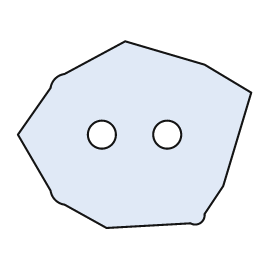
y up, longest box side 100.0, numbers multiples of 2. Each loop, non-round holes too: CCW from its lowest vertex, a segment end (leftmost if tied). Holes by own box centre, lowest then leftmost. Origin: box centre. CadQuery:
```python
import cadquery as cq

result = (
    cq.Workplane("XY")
    .moveTo(-12.0, -40.0)
    .lineTo(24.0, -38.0)
    .threePointArc((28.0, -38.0), (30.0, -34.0))
    .lineTo(38.0, -22.0)
    .lineTo(50.0, 18.0)
    .lineTo(30.0, 30.0)
    .lineTo(-4.0, 40.0)
    .lineTo(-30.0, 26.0)
    .threePointArc((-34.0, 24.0), (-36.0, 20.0))
    .lineTo(-50.0, 0.0)
    .lineTo(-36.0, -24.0)
    .threePointArc((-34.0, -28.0), (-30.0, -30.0))
    .close()
    .moveTo(-14.0, 0.0)
    .circle(6.0)
    .moveTo(14.0, 0.0)
    .circle(6.0)
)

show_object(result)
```